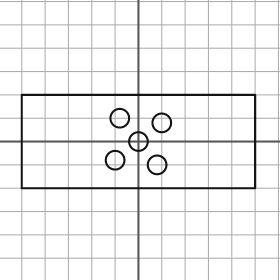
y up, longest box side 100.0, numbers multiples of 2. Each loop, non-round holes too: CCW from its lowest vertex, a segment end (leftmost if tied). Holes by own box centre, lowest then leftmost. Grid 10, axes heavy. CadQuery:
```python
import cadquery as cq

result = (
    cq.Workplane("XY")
    .moveTo(-50.0, -20.0)
    .lineTo(50.0, -20.0)
    .lineTo(50.0, 20.0)
    .lineTo(-50.0, 20.0)
    .close()
    .moveTo(8.0, -10.0)
    .circle(4.0)
    .moveTo(-10.0, -8.0)
    .circle(4.0)
    .moveTo(0.0, 0.0)
    .circle(4.0)
    .moveTo(10.0, 8.0)
    .circle(4.0)
    .moveTo(-8.0, 10.0)
    .circle(4.0)
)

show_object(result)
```